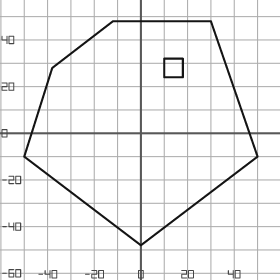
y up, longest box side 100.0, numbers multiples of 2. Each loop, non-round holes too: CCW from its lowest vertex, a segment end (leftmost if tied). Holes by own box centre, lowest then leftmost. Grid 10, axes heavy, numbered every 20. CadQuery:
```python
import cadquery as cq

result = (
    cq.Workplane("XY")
    .moveTo(0.0, -48.0)
    .lineTo(50.0, -10.0)
    .lineTo(30.0, 48.0)
    .lineTo(-12.0, 48.0)
    .lineTo(-38.0, 28.0)
    .lineTo(-50.0, -10.0)
    .close()
    .moveTo(10.0, 24.0)
    .lineTo(18.0, 24.0)
    .lineTo(18.0, 32.0)
    .lineTo(10.0, 32.0)
    .close()
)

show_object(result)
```